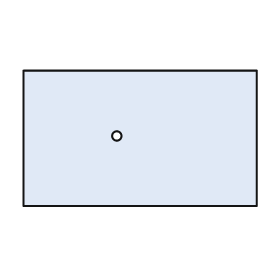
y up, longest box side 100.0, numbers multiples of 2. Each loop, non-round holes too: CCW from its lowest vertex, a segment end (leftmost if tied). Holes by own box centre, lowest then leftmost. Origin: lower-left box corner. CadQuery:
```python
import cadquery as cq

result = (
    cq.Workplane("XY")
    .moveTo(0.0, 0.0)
    .lineTo(100.0, 0.0)
    .lineTo(100.0, 58.0)
    .lineTo(0.0, 58.0)
    .close()
    .moveTo(40.0, 30.0)
    .circle(2.0)
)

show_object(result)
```